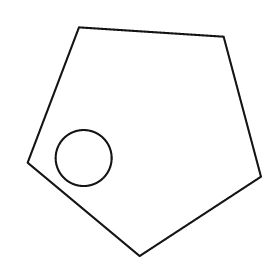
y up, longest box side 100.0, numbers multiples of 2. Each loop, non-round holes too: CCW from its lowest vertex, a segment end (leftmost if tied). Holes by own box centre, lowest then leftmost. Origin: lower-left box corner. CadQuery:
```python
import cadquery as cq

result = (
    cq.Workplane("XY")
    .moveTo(48.0, 0.0)
    .lineTo(100.0, 34.0)
    .lineTo(84.0, 94.0)
    .lineTo(22.0, 98.0)
    .lineTo(0.0, 40.0)
    .close()
    .moveTo(24.0, 42.0)
    .circle(12.0)
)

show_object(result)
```